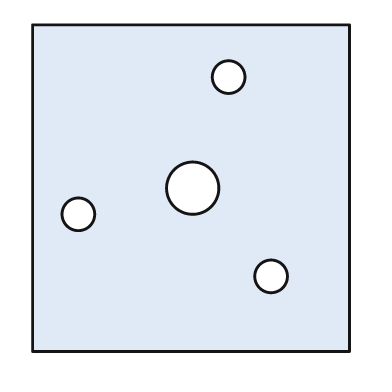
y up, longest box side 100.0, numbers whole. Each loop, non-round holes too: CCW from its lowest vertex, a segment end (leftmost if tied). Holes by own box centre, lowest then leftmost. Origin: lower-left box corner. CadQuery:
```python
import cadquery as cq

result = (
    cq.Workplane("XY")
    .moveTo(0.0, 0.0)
    .lineTo(97.0, 0.0)
    .lineTo(97.0, 100.0)
    .lineTo(0.0, 100.0)
    .close()
    .moveTo(73.0, 23.0)
    .circle(5.0)
    .moveTo(14.0, 42.0)
    .circle(5.0)
    .moveTo(49.0, 50.0)
    .circle(8.0)
    .moveTo(60.0, 84.0)
    .circle(5.0)
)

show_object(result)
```